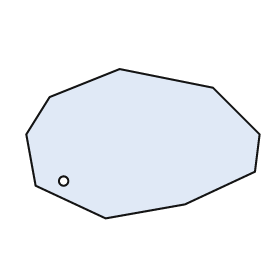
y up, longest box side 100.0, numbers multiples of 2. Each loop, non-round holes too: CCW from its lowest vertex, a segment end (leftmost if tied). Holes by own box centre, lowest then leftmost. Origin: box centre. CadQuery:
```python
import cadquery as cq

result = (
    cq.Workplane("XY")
    .moveTo(-16.0, -32.0)
    .lineTo(18.0, -26.0)
    .lineTo(48.0, -12.0)
    .lineTo(50.0, 4.0)
    .lineTo(30.0, 24.0)
    .lineTo(-10.0, 32.0)
    .lineTo(-40.0, 20.0)
    .lineTo(-50.0, 4.0)
    .lineTo(-46.0, -18.0)
    .close()
    .moveTo(-34.0, -16.0)
    .circle(2.0)
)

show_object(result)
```